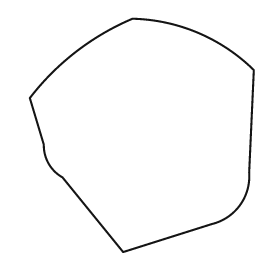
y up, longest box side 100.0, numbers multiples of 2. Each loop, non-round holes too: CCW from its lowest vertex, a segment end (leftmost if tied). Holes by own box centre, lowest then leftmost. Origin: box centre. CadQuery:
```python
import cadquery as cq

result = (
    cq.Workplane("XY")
    .moveTo(-8.0, -50.0)
    .lineTo(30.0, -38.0)
    .threePointArc((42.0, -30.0), (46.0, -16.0))
    .lineTo(48.0, 28.0)
    .threePointArc((24.0, 44.0), (-4.0, 50.0))
    .threePointArc((-28.0, 36.0), (-48.0, 16.0))
    .lineTo(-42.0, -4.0)
    .threePointArc((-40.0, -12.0), (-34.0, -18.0))
    .close()
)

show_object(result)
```